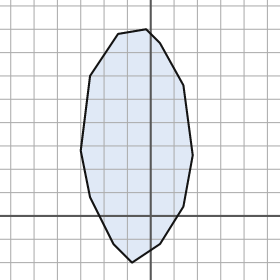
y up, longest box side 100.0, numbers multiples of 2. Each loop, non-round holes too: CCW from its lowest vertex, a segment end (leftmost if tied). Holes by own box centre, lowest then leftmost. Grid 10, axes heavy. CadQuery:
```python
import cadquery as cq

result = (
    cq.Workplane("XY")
    .moveTo(-8.0, -20.0)
    .lineTo(4.0, -12.0)
    .lineTo(14.0, 4.0)
    .lineTo(18.0, 26.0)
    .lineTo(14.0, 56.0)
    .lineTo(4.0, 74.0)
    .lineTo(-2.0, 80.0)
    .lineTo(-14.0, 78.0)
    .lineTo(-26.0, 60.0)
    .lineTo(-30.0, 28.0)
    .lineTo(-26.0, 8.0)
    .lineTo(-16.0, -12.0)
    .close()
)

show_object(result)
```